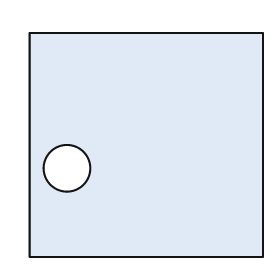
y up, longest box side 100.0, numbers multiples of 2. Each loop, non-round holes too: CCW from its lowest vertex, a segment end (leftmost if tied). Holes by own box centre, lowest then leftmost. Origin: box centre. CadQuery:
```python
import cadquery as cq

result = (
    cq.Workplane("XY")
    .moveTo(-50.0, -48.0)
    .lineTo(50.0, -48.0)
    .lineTo(50.0, 48.0)
    .lineTo(-50.0, 48.0)
    .close()
    .moveTo(-34.0, -10.0)
    .circle(10.0)
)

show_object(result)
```